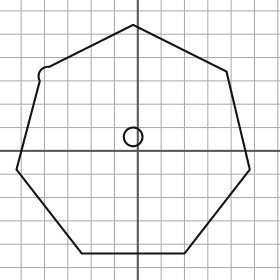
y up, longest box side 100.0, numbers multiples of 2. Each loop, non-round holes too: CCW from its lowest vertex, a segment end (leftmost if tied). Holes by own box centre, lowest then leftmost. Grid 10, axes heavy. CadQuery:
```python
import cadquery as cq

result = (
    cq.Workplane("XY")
    .moveTo(-24.0, -44.0)
    .lineTo(20.0, -44.0)
    .lineTo(48.0, -8.0)
    .lineTo(38.0, 34.0)
    .lineTo(-2.0, 54.0)
    .lineTo(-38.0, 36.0)
    .threePointArc((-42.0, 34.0), (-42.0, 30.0))
    .lineTo(-52.0, -8.0)
    .close()
    .moveTo(-2.0, 6.0)
    .circle(4.0)
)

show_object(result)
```